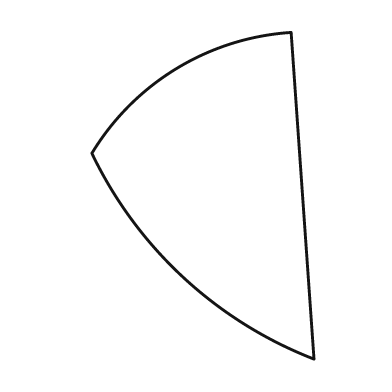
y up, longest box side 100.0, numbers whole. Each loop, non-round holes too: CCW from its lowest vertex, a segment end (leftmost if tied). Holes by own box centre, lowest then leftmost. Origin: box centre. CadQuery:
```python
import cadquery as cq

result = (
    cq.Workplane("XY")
    .moveTo(34.0, -50.0)
    .lineTo(27.0, 50.0)
    .threePointArc((-8.0, 39.0), (-34.0, 13.0))
    .threePointArc((-6.0, -25.0), (34.0, -50.0))
    .close()
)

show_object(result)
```